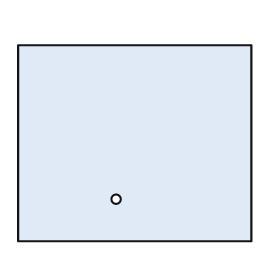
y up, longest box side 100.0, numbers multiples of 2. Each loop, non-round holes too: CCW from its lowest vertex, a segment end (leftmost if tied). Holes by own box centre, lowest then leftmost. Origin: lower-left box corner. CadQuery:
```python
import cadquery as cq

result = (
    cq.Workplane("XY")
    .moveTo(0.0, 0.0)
    .lineTo(100.0, 0.0)
    .lineTo(100.0, 84.0)
    .lineTo(0.0, 84.0)
    .close()
    .moveTo(42.0, 18.0)
    .circle(2.0)
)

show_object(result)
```